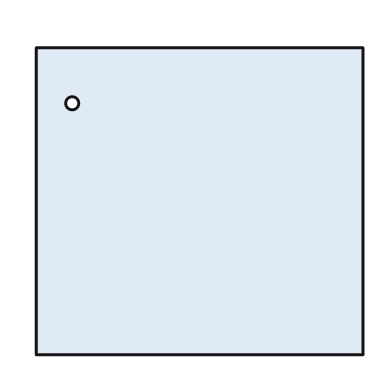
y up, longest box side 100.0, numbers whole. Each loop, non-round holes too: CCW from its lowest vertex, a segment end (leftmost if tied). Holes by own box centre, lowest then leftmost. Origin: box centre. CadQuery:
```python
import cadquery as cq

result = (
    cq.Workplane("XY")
    .moveTo(-50.0, -47.0)
    .lineTo(50.0, -47.0)
    .lineTo(50.0, 47.0)
    .lineTo(-50.0, 47.0)
    .close()
    .moveTo(-39.0, 30.0)
    .circle(2.0)
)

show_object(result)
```